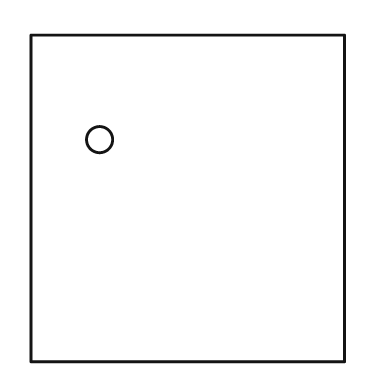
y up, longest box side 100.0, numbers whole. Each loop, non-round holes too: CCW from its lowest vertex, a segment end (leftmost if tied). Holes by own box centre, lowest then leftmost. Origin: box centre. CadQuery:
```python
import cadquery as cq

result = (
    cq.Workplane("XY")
    .moveTo(-48.0, -50.0)
    .lineTo(48.0, -50.0)
    .lineTo(48.0, 50.0)
    .lineTo(-48.0, 50.0)
    .close()
    .moveTo(-27.0, 18.0)
    .circle(4.0)
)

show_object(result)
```